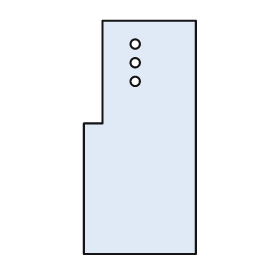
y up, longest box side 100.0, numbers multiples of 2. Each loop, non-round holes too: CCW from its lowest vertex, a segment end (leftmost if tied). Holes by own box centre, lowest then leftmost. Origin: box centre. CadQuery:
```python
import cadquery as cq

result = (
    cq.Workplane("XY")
    .moveTo(-24.0, -50.0)
    .lineTo(24.0, -50.0)
    .lineTo(24.0, 50.0)
    .lineTo(-16.0, 50.0)
    .lineTo(-16.0, 6.0)
    .lineTo(-24.0, 6.0)
    .close()
    .moveTo(-2.0, 24.0)
    .circle(2.0)
    .moveTo(-2.0, 32.0)
    .circle(2.0)
    .moveTo(-2.0, 40.0)
    .circle(2.0)
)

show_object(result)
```